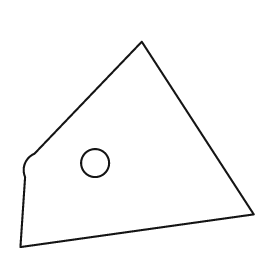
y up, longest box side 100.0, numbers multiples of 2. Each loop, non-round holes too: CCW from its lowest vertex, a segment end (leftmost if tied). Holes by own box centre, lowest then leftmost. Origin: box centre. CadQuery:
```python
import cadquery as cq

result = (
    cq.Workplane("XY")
    .moveTo(-50.0, -44.0)
    .lineTo(50.0, -30.0)
    .lineTo(2.0, 44.0)
    .lineTo(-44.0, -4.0)
    .threePointArc((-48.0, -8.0), (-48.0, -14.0))
    .close()
    .moveTo(-18.0, -8.0)
    .circle(6.0)
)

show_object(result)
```